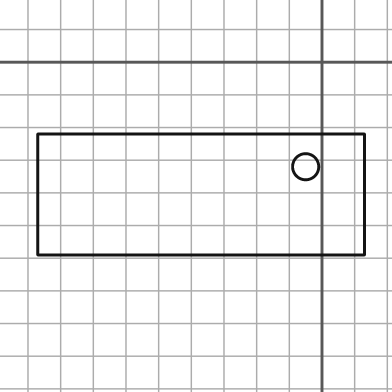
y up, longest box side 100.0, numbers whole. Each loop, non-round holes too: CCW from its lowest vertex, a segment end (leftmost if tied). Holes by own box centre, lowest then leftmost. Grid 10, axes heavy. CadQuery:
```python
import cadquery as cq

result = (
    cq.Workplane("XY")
    .moveTo(-87.0, -59.0)
    .lineTo(13.0, -59.0)
    .lineTo(13.0, -22.0)
    .lineTo(-87.0, -22.0)
    .close()
    .moveTo(-5.0, -32.0)
    .circle(4.0)
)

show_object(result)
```